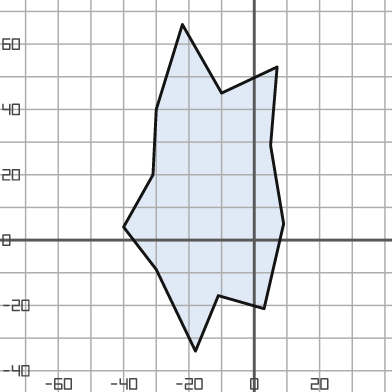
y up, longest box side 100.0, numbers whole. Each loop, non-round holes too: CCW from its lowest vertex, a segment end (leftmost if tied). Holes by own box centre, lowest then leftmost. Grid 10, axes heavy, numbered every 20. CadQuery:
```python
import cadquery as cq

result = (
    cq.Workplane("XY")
    .moveTo(-18.0, -34.0)
    .lineTo(-11.0, -17.0)
    .lineTo(3.0, -21.0)
    .lineTo(9.0, 5.0)
    .lineTo(5.0, 29.0)
    .lineTo(7.0, 53.0)
    .lineTo(-10.0, 45.0)
    .lineTo(-22.0, 66.0)
    .lineTo(-30.0, 40.0)
    .lineTo(-31.0, 20.0)
    .lineTo(-40.0, 4.0)
    .lineTo(-30.0, -9.0)
    .close()
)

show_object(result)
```